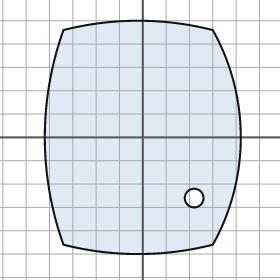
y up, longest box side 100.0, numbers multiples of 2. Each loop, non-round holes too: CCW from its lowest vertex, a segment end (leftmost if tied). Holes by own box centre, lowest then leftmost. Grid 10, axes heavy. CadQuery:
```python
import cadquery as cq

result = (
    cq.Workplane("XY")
    .moveTo(-34.0, -46.0)
    .threePointArc((-2.0, -50.0), (30.0, -46.0))
    .threePointArc((42.0, 0.0), (30.0, 46.0))
    .threePointArc((-2.0, 50.0), (-34.0, 46.0))
    .threePointArc((-42.0, 0.0), (-34.0, -46.0))
    .close()
    .moveTo(22.0, -26.0)
    .circle(4.0)
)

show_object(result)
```